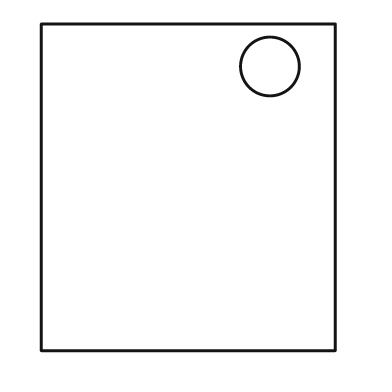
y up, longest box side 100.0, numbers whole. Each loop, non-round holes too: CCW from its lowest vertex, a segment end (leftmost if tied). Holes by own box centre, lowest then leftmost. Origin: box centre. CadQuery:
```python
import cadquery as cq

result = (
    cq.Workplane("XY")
    .moveTo(-45.0, -50.0)
    .lineTo(45.0, -50.0)
    .lineTo(45.0, 50.0)
    .lineTo(-45.0, 50.0)
    .close()
    .moveTo(25.0, 37.0)
    .circle(9.0)
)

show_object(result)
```